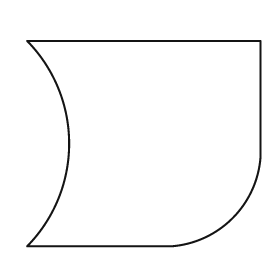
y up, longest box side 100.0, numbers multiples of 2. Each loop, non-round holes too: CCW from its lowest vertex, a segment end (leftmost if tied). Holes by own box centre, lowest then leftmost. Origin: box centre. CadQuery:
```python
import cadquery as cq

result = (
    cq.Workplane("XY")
    .moveTo(-50.0, -44.0)
    .lineTo(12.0, -44.0)
    .threePointArc((38.0, -32.0), (50.0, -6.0))
    .lineTo(50.0, 44.0)
    .lineTo(-50.0, 44.0)
    .threePointArc((-32.0, 0.0), (-50.0, -44.0))
    .close()
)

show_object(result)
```